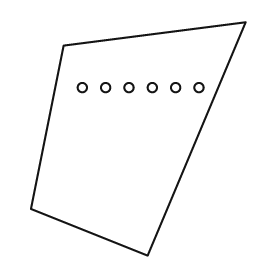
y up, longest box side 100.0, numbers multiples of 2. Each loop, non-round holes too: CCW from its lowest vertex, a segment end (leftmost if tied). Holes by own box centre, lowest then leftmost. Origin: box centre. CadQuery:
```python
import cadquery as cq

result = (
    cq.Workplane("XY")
    .moveTo(4.0, -50.0)
    .lineTo(46.0, 50.0)
    .lineTo(-32.0, 40.0)
    .lineTo(-46.0, -30.0)
    .close()
    .moveTo(-24.0, 22.0)
    .circle(2.0)
    .moveTo(-14.0, 22.0)
    .circle(2.0)
    .moveTo(-4.0, 22.0)
    .circle(2.0)
    .moveTo(6.0, 22.0)
    .circle(2.0)
    .moveTo(16.0, 22.0)
    .circle(2.0)
    .moveTo(26.0, 22.0)
    .circle(2.0)
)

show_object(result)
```